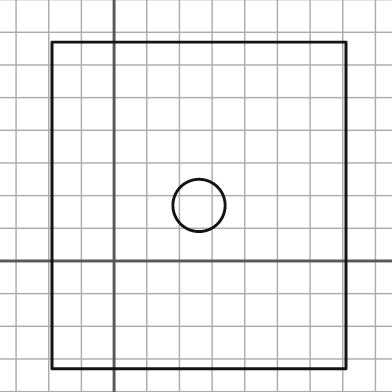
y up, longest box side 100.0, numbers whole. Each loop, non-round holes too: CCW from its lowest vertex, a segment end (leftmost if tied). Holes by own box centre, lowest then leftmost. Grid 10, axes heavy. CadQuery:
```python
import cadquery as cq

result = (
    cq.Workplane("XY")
    .moveTo(-19.0, -33.0)
    .lineTo(71.0, -33.0)
    .lineTo(71.0, 67.0)
    .lineTo(-19.0, 67.0)
    .close()
    .moveTo(26.0, 17.0)
    .circle(8.0)
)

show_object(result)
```